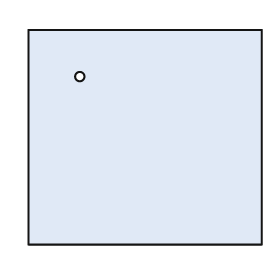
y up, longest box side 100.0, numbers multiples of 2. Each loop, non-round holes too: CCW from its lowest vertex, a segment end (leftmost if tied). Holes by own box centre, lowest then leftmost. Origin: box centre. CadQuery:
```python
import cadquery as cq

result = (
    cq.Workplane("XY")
    .moveTo(-50.0, -46.0)
    .lineTo(50.0, -46.0)
    .lineTo(50.0, 46.0)
    .lineTo(-50.0, 46.0)
    .close()
    .moveTo(-28.0, 26.0)
    .circle(2.0)
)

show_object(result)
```